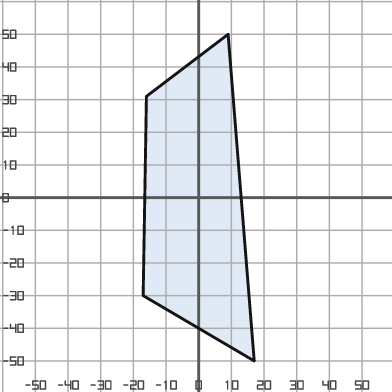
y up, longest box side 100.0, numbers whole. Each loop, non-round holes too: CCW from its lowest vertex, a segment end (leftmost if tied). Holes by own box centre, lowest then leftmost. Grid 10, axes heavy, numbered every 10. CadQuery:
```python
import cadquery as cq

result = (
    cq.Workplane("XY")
    .moveTo(17.0, -50.0)
    .lineTo(9.0, 50.0)
    .lineTo(-16.0, 31.0)
    .lineTo(-17.0, -30.0)
    .close()
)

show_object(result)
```